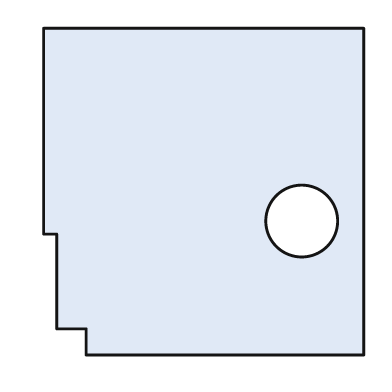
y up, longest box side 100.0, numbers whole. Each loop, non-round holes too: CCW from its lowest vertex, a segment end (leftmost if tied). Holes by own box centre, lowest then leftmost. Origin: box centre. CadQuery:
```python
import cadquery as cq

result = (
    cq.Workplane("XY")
    .moveTo(-36.0, -50.0)
    .lineTo(49.0, -50.0)
    .lineTo(49.0, 50.0)
    .lineTo(-49.0, 50.0)
    .lineTo(-49.0, -13.0)
    .lineTo(-45.0, -13.0)
    .lineTo(-45.0, -42.0)
    .lineTo(-36.0, -42.0)
    .close()
    .moveTo(30.0, -9.0)
    .circle(11.0)
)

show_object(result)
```